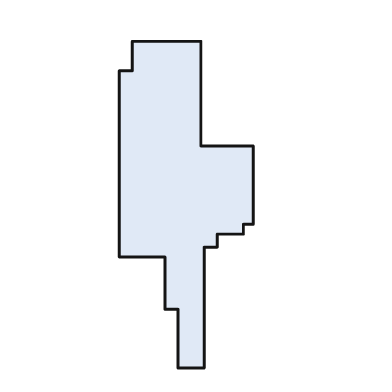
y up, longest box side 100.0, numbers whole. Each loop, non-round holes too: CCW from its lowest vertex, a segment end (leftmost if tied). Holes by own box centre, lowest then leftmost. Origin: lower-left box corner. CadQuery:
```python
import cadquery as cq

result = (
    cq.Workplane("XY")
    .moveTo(18.0, 0.0)
    .lineTo(26.0, 0.0)
    .lineTo(26.0, 37.0)
    .lineTo(30.0, 37.0)
    .lineTo(30.0, 41.0)
    .lineTo(38.0, 41.0)
    .lineTo(38.0, 44.0)
    .lineTo(41.0, 44.0)
    .lineTo(41.0, 68.0)
    .lineTo(25.0, 68.0)
    .lineTo(25.0, 100.0)
    .lineTo(4.0, 100.0)
    .lineTo(4.0, 91.0)
    .lineTo(0.0, 91.0)
    .lineTo(0.0, 34.0)
    .lineTo(14.0, 34.0)
    .lineTo(14.0, 18.0)
    .lineTo(18.0, 18.0)
    .close()
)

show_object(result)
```